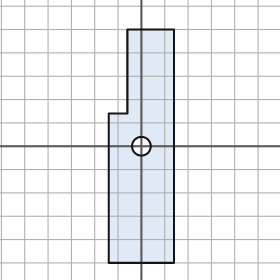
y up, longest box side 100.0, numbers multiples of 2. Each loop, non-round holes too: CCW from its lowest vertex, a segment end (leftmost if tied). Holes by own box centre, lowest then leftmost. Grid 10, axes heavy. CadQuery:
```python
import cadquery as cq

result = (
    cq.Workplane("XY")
    .moveTo(-14.0, -50.0)
    .lineTo(14.0, -50.0)
    .lineTo(14.0, 50.0)
    .lineTo(-6.0, 50.0)
    .lineTo(-6.0, 14.0)
    .lineTo(-14.0, 14.0)
    .close()
    .moveTo(0.0, 0.0)
    .circle(4.0)
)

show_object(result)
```